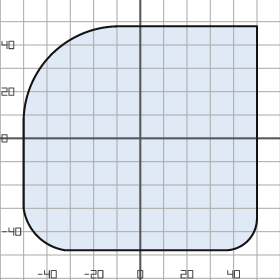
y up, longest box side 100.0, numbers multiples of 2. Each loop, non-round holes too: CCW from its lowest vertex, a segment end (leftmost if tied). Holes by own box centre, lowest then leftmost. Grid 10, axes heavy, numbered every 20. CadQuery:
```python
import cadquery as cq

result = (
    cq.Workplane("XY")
    .moveTo(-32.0, -48.0)
    .lineTo(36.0, -48.0)
    .threePointArc((46.0, -44.0), (50.0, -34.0))
    .lineTo(50.0, 48.0)
    .lineTo(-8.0, 48.0)
    .threePointArc((-38.0, 36.0), (-50.0, 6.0))
    .lineTo(-50.0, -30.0)
    .threePointArc((-44.0, -42.0), (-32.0, -48.0))
    .close()
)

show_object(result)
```